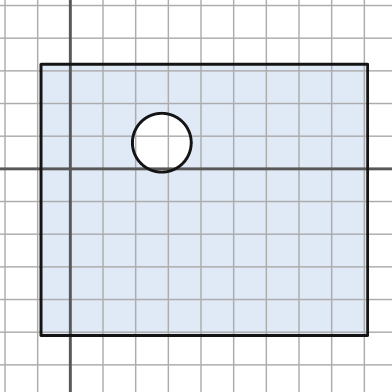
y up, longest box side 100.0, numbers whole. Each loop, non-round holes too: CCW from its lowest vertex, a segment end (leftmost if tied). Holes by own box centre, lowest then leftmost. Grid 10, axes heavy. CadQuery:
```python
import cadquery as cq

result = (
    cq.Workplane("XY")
    .moveTo(-9.0, -51.0)
    .lineTo(91.0, -51.0)
    .lineTo(91.0, 32.0)
    .lineTo(-9.0, 32.0)
    .close()
    .moveTo(28.0, 8.0)
    .circle(9.0)
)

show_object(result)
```